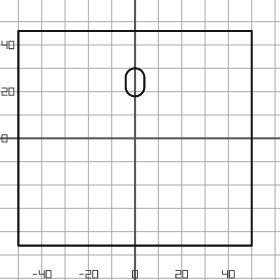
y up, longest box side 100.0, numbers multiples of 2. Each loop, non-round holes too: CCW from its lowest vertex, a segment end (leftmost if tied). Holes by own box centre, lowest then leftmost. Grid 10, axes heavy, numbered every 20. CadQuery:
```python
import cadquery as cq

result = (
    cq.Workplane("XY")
    .moveTo(-50.0, -46.0)
    .lineTo(50.0, -46.0)
    .lineTo(50.0, 46.0)
    .lineTo(-50.0, 46.0)
    .close()
    .moveTo(-4.0, 22.0)
    .threePointArc((0.0, 18.0), (4.0, 22.0))
    .lineTo(4.0, 26.0)
    .threePointArc((0.0, 30.0), (-4.0, 26.0))
    .close()
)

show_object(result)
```